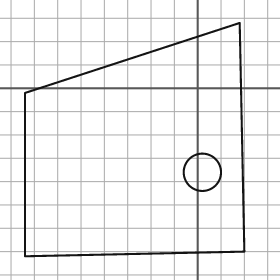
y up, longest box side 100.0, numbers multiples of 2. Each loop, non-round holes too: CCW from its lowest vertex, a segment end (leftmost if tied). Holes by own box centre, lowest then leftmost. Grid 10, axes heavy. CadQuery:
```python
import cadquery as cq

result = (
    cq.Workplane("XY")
    .moveTo(-74.0, -72.0)
    .lineTo(20.0, -70.0)
    .lineTo(18.0, 28.0)
    .lineTo(-74.0, -2.0)
    .close()
    .moveTo(2.0, -36.0)
    .circle(8.0)
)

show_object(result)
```